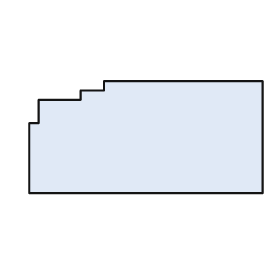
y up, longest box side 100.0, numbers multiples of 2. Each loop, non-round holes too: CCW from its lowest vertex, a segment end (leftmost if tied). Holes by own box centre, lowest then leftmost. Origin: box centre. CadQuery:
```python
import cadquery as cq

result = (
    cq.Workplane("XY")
    .moveTo(-50.0, -24.0)
    .lineTo(50.0, -24.0)
    .lineTo(50.0, 24.0)
    .lineTo(-18.0, 24.0)
    .lineTo(-18.0, 20.0)
    .lineTo(-28.0, 20.0)
    .lineTo(-28.0, 16.0)
    .lineTo(-46.0, 16.0)
    .lineTo(-46.0, 6.0)
    .lineTo(-50.0, 6.0)
    .close()
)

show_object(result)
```